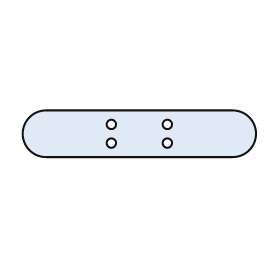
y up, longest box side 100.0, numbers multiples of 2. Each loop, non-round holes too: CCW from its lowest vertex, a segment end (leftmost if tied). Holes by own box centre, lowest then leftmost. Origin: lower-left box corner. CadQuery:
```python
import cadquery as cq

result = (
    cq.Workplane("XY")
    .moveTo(10.0, 0.0)
    .lineTo(90.0, 0.0)
    .threePointArc((100.0, 10.0), (90.0, 20.0))
    .lineTo(10.0, 20.0)
    .threePointArc((0.0, 10.0), (10.0, 0.0))
    .close()
    .moveTo(38.0, 6.0)
    .circle(2.0)
    .moveTo(62.0, 6.0)
    .circle(2.0)
    .moveTo(38.0, 14.0)
    .circle(2.0)
    .moveTo(62.0, 14.0)
    .circle(2.0)
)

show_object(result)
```